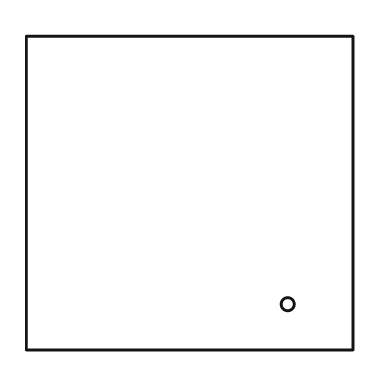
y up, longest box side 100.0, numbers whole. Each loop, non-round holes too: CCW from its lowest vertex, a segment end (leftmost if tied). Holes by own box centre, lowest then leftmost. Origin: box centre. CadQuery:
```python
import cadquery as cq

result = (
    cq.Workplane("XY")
    .moveTo(-50.0, -48.0)
    .lineTo(50.0, -48.0)
    .lineTo(50.0, 48.0)
    .lineTo(-50.0, 48.0)
    .close()
    .moveTo(30.0, -34.0)
    .circle(2.0)
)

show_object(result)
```